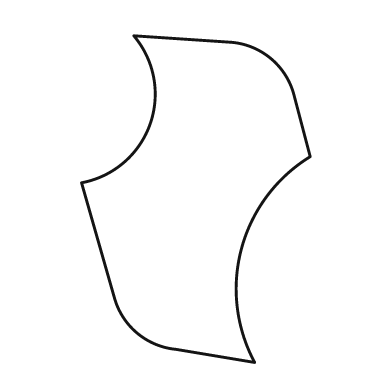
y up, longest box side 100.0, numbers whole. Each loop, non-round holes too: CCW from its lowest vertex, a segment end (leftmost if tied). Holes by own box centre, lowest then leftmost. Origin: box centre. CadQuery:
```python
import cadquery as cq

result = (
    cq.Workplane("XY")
    .moveTo(18.0, -50.0)
    .threePointArc((14.0, -15.0), (35.0, 13.0))
    .lineTo(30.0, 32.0)
    .threePointArc((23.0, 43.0), (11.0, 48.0))
    .lineTo(-19.0, 50.0)
    .threePointArc((-14.0, 23.0), (-35.0, 5.0))
    .lineTo(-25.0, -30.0)
    .threePointArc((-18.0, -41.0), (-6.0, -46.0))
    .close()
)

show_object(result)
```